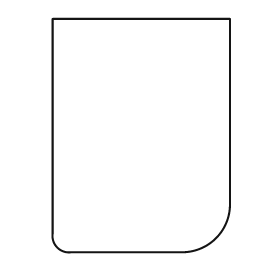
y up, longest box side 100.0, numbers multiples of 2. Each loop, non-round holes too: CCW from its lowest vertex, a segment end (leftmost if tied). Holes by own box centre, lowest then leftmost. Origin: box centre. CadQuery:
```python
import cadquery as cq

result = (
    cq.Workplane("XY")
    .moveTo(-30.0, -50.0)
    .lineTo(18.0, -50.0)
    .threePointArc((32.0, -44.0), (38.0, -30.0))
    .lineTo(38.0, 50.0)
    .lineTo(-38.0, 50.0)
    .lineTo(-38.0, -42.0)
    .threePointArc((-36.0, -48.0), (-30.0, -50.0))
    .close()
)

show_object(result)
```